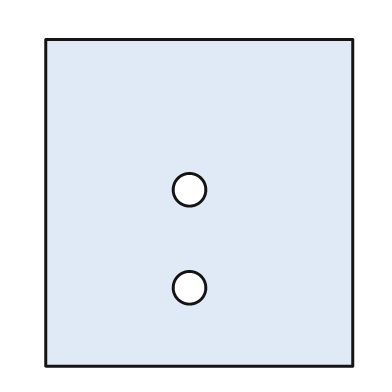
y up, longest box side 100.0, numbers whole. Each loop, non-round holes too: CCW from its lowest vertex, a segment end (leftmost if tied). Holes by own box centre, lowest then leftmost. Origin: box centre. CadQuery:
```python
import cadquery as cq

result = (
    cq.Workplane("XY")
    .moveTo(-47.0, -50.0)
    .lineTo(47.0, -50.0)
    .lineTo(47.0, 50.0)
    .lineTo(-47.0, 50.0)
    .close()
    .moveTo(-3.0, -26.0)
    .circle(5.0)
    .moveTo(-3.0, 4.0)
    .circle(5.0)
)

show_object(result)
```